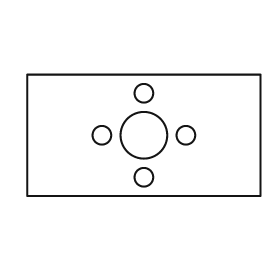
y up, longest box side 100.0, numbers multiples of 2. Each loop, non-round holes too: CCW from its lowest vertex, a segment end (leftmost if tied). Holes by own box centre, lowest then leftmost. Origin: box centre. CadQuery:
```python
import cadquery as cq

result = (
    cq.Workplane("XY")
    .moveTo(-50.0, -26.0)
    .lineTo(50.0, -26.0)
    .lineTo(50.0, 26.0)
    .lineTo(-50.0, 26.0)
    .close()
    .moveTo(0.0, -18.0)
    .circle(4.0)
    .moveTo(-18.0, 0.0)
    .circle(4.0)
    .moveTo(0.0, 0.0)
    .circle(10.0)
    .moveTo(18.0, 0.0)
    .circle(4.0)
    .moveTo(0.0, 18.0)
    .circle(4.0)
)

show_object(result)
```